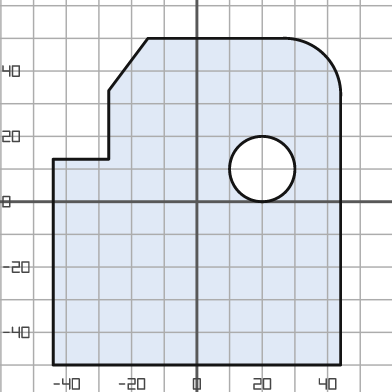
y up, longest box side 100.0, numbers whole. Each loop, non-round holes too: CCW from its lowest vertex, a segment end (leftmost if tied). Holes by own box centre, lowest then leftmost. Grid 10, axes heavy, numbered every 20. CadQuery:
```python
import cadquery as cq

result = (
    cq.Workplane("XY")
    .moveTo(-44.0, -50.0)
    .lineTo(44.0, -50.0)
    .lineTo(44.0, 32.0)
    .threePointArc((39.0, 45.0), (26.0, 50.0))
    .lineTo(-15.0, 50.0)
    .lineTo(-27.0, 34.0)
    .lineTo(-27.0, 13.0)
    .lineTo(-44.0, 13.0)
    .close()
    .moveTo(20.0, 10.0)
    .circle(10.0)
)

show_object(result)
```